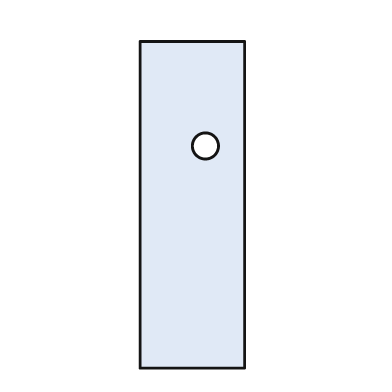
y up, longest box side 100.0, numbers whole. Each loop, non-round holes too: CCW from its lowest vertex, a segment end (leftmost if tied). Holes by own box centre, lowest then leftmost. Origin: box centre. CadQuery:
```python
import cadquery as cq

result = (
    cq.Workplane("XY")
    .moveTo(-16.0, -50.0)
    .lineTo(16.0, -50.0)
    .lineTo(16.0, 50.0)
    .lineTo(-16.0, 50.0)
    .close()
    .moveTo(4.0, 18.0)
    .circle(4.0)
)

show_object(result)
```